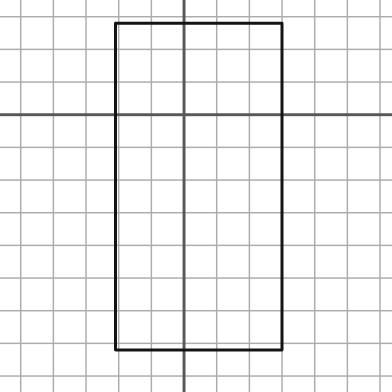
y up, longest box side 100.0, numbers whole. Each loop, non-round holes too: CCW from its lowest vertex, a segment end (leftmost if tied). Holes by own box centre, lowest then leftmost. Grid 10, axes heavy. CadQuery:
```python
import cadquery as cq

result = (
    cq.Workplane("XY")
    .moveTo(-21.0, -72.0)
    .lineTo(30.0, -72.0)
    .lineTo(30.0, 28.0)
    .lineTo(-21.0, 28.0)
    .close()
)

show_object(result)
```